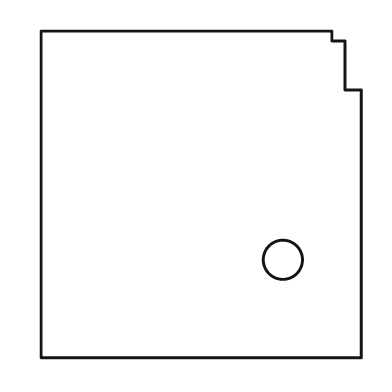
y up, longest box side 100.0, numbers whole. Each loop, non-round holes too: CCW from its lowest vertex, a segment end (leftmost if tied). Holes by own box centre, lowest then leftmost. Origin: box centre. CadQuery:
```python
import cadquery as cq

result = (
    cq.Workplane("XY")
    .moveTo(-49.0, -50.0)
    .lineTo(49.0, -50.0)
    .lineTo(49.0, 32.0)
    .lineTo(44.0, 32.0)
    .lineTo(44.0, 47.0)
    .lineTo(40.0, 47.0)
    .lineTo(40.0, 50.0)
    .lineTo(-49.0, 50.0)
    .close()
    .moveTo(25.0, -20.0)
    .circle(6.0)
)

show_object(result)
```